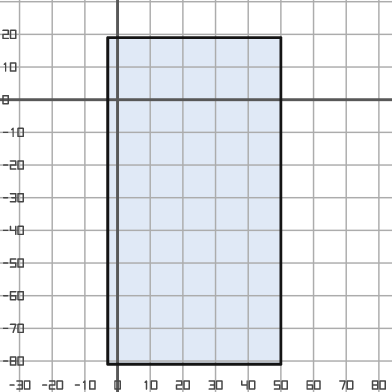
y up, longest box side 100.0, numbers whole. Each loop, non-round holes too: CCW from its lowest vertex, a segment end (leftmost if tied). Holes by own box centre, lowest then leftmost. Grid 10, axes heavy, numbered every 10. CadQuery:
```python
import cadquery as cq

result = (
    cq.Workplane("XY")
    .moveTo(-3.0, -81.0)
    .lineTo(50.0, -81.0)
    .lineTo(50.0, 19.0)
    .lineTo(-3.0, 19.0)
    .close()
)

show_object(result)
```